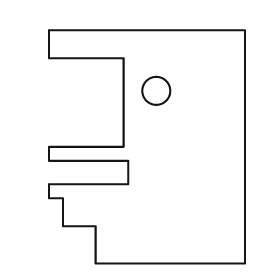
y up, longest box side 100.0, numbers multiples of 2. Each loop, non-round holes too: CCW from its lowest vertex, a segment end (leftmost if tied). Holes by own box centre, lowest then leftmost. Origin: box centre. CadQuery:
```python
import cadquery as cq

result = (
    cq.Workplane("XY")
    .moveTo(-22.0, -50.0)
    .lineTo(42.0, -50.0)
    .lineTo(42.0, 50.0)
    .lineTo(-42.0, 50.0)
    .lineTo(-42.0, 38.0)
    .lineTo(-10.0, 38.0)
    .lineTo(-10.0, 0.0)
    .lineTo(-42.0, 0.0)
    .lineTo(-42.0, -6.0)
    .lineTo(-8.0, -6.0)
    .lineTo(-8.0, -16.0)
    .lineTo(-42.0, -16.0)
    .lineTo(-42.0, -22.0)
    .lineTo(-36.0, -22.0)
    .lineTo(-36.0, -34.0)
    .lineTo(-22.0, -34.0)
    .close()
    .moveTo(4.0, 24.0)
    .circle(6.0)
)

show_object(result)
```